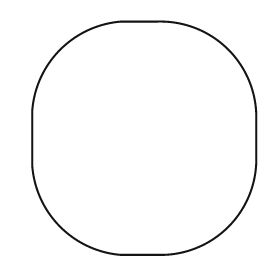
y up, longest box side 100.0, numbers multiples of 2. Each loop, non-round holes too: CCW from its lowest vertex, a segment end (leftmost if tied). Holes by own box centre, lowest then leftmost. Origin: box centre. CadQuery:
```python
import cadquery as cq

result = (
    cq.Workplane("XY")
    .moveTo(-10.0, -50.0)
    .lineTo(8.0, -50.0)
    .threePointArc((36.0, -38.0), (48.0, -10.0))
    .lineTo(48.0, 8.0)
    .threePointArc((36.0, 38.0), (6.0, 50.0))
    .lineTo(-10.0, 50.0)
    .threePointArc((-36.0, 38.0), (-48.0, 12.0))
    .lineTo(-48.0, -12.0)
    .threePointArc((-36.0, -38.0), (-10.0, -50.0))
    .close()
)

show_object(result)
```